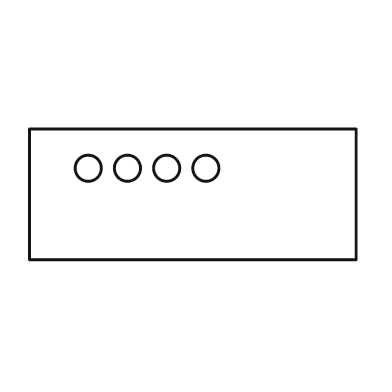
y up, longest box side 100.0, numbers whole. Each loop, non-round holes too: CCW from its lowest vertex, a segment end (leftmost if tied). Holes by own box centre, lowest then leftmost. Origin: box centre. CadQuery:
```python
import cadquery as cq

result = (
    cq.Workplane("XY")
    .moveTo(-50.0, -20.0)
    .lineTo(50.0, -20.0)
    .lineTo(50.0, 20.0)
    .lineTo(-50.0, 20.0)
    .close()
    .moveTo(-32.0, 8.0)
    .circle(4.0)
    .moveTo(-20.0, 8.0)
    .circle(4.0)
    .moveTo(-8.0, 8.0)
    .circle(4.0)
    .moveTo(4.0, 8.0)
    .circle(4.0)
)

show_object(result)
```